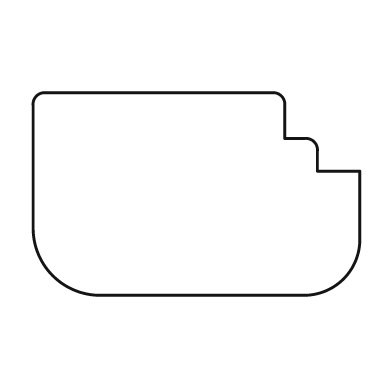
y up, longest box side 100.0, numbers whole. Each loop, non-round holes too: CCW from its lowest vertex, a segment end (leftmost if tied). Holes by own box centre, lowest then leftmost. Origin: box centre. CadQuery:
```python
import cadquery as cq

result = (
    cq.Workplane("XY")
    .moveTo(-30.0, -31.0)
    .lineTo(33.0, -31.0)
    .threePointArc((45.0, -26.0), (50.0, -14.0))
    .lineTo(50.0, 7.0)
    .lineTo(37.0, 7.0)
    .lineTo(37.0, 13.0)
    .threePointArc((36.0, 16.0), (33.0, 17.0))
    .lineTo(27.0, 17.0)
    .lineTo(27.0, 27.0)
    .threePointArc((26.0, 30.0), (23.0, 31.0))
    .lineTo(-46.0, 31.0)
    .threePointArc((-49.0, 30.0), (-50.0, 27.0))
    .lineTo(-50.0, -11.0)
    .threePointArc((-44.0, -25.0), (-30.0, -31.0))
    .close()
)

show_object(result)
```